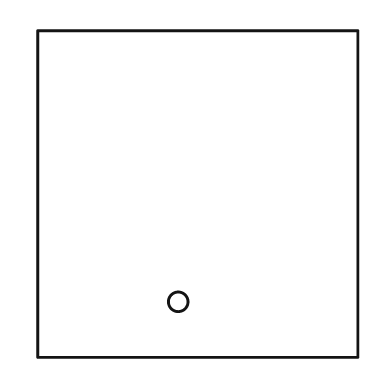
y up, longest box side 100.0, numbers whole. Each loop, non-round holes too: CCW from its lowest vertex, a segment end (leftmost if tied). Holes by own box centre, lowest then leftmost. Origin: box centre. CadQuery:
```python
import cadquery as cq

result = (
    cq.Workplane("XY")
    .moveTo(-49.0, -50.0)
    .lineTo(49.0, -50.0)
    .lineTo(49.0, 50.0)
    .lineTo(-49.0, 50.0)
    .close()
    .moveTo(-6.0, -33.0)
    .circle(3.0)
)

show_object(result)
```